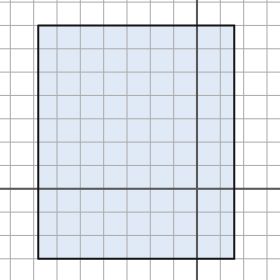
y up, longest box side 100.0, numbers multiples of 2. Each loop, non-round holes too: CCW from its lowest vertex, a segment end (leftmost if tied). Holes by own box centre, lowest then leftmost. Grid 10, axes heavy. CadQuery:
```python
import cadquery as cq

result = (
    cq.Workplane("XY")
    .moveTo(-68.0, -30.0)
    .lineTo(16.0, -30.0)
    .lineTo(16.0, 70.0)
    .lineTo(-68.0, 70.0)
    .close()
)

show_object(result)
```